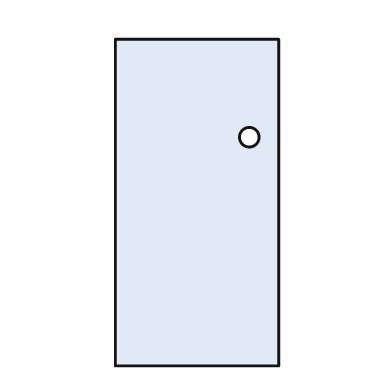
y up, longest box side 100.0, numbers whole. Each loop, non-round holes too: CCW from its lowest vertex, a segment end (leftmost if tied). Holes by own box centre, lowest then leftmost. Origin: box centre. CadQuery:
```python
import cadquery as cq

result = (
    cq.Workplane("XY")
    .moveTo(-25.0, -50.0)
    .lineTo(25.0, -50.0)
    .lineTo(25.0, 50.0)
    .lineTo(-25.0, 50.0)
    .close()
    .moveTo(16.0, 20.0)
    .circle(3.0)
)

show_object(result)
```